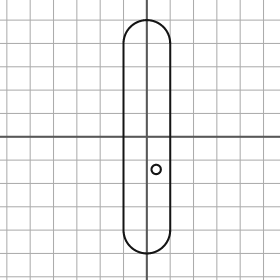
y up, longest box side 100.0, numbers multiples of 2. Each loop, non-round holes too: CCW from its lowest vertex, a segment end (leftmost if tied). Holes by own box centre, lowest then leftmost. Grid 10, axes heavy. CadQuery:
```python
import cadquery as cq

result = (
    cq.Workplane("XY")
    .moveTo(-10.0, -40.0)
    .threePointArc((0.0, -50.0), (10.0, -40.0))
    .lineTo(10.0, 40.0)
    .threePointArc((0.0, 50.0), (-10.0, 40.0))
    .close()
    .moveTo(4.0, -14.0)
    .circle(2.0)
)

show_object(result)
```